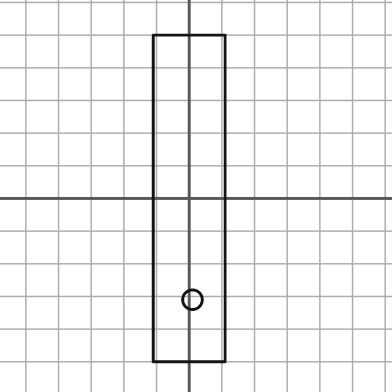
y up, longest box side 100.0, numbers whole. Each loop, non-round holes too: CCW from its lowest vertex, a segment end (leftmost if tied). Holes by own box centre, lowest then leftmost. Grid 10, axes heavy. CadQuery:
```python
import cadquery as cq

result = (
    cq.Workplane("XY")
    .moveTo(-11.0, -50.0)
    .lineTo(11.0, -50.0)
    .lineTo(11.0, 50.0)
    .lineTo(-11.0, 50.0)
    .close()
    .moveTo(1.0, -31.0)
    .circle(3.0)
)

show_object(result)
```